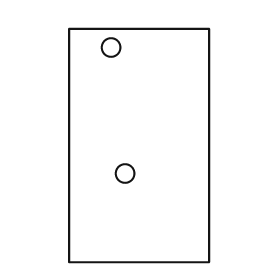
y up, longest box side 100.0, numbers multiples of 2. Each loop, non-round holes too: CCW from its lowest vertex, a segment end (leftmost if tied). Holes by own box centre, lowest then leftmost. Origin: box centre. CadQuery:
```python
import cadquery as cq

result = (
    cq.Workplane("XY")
    .moveTo(-30.0, -50.0)
    .lineTo(30.0, -50.0)
    .lineTo(30.0, 50.0)
    .lineTo(-30.0, 50.0)
    .close()
    .moveTo(-6.0, -12.0)
    .circle(4.0)
    .moveTo(-12.0, 42.0)
    .circle(4.0)
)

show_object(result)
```